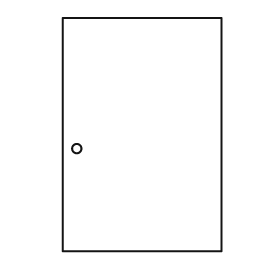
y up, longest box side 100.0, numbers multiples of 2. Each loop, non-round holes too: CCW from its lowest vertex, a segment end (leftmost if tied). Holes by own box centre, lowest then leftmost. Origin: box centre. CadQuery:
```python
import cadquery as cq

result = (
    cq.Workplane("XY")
    .moveTo(-34.0, -50.0)
    .lineTo(34.0, -50.0)
    .lineTo(34.0, 50.0)
    .lineTo(-34.0, 50.0)
    .close()
    .moveTo(-28.0, -6.0)
    .circle(2.0)
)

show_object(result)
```